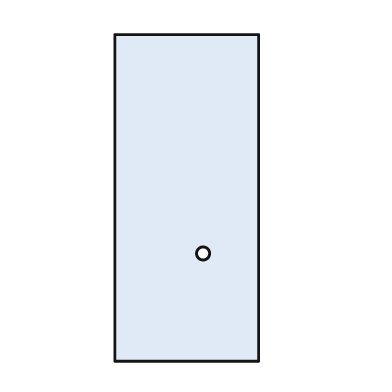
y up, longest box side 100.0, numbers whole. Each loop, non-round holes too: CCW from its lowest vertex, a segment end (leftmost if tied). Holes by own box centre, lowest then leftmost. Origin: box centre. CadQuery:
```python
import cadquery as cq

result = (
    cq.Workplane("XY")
    .moveTo(-22.0, -50.0)
    .lineTo(22.0, -50.0)
    .lineTo(22.0, 50.0)
    .lineTo(-22.0, 50.0)
    .close()
    .moveTo(5.0, -17.0)
    .circle(2.0)
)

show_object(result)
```